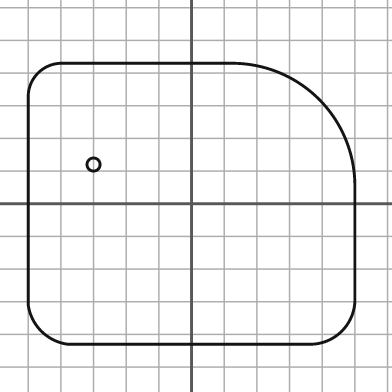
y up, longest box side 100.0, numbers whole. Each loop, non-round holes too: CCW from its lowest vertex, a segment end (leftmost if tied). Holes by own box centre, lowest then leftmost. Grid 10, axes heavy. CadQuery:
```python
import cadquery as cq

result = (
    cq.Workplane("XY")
    .moveTo(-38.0, -43.0)
    .lineTo(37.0, -43.0)
    .threePointArc((46.0, -39.0), (50.0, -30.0))
    .lineTo(50.0, 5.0)
    .threePointArc((39.0, 32.0), (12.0, 43.0))
    .lineTo(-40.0, 43.0)
    .threePointArc((-47.0, 40.0), (-50.0, 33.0))
    .lineTo(-50.0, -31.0)
    .threePointArc((-46.0, -39.0), (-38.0, -43.0))
    .close()
    .moveTo(-30.0, 12.0)
    .circle(2.0)
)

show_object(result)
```